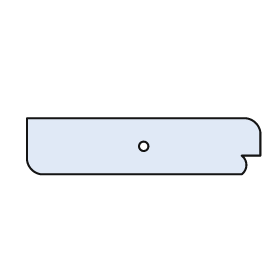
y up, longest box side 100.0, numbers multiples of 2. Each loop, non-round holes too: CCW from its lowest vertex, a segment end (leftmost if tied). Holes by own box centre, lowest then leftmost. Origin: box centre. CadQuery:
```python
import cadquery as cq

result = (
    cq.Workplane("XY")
    .moveTo(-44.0, -12.0)
    .lineTo(42.0, -12.0)
    .threePointArc((44.0, -8.0), (42.0, -4.0))
    .lineTo(50.0, -4.0)
    .lineTo(50.0, 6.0)
    .threePointArc((48.0, 10.0), (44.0, 12.0))
    .lineTo(-50.0, 12.0)
    .lineTo(-50.0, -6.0)
    .threePointArc((-48.0, -10.0), (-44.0, -12.0))
    .close()
    .moveTo(0.0, 0.0)
    .circle(2.0)
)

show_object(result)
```